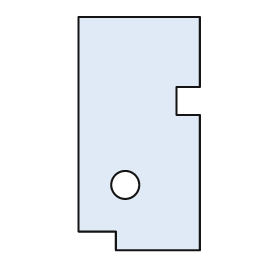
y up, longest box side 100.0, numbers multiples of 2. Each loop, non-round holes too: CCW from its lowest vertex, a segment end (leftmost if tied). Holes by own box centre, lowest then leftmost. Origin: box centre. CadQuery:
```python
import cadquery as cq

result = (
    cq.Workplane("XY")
    .moveTo(-10.0, -50.0)
    .lineTo(26.0, -50.0)
    .lineTo(26.0, 8.0)
    .lineTo(16.0, 8.0)
    .lineTo(16.0, 20.0)
    .lineTo(26.0, 20.0)
    .lineTo(26.0, 50.0)
    .lineTo(-26.0, 50.0)
    .lineTo(-26.0, -42.0)
    .lineTo(-10.0, -42.0)
    .close()
    .moveTo(-6.0, -22.0)
    .circle(6.0)
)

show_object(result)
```